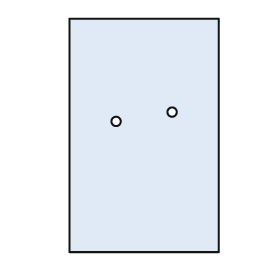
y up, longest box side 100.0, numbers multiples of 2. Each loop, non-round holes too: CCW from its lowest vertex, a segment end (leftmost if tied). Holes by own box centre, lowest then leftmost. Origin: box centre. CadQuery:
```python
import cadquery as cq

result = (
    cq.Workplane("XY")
    .moveTo(-32.0, -50.0)
    .lineTo(32.0, -50.0)
    .lineTo(32.0, 50.0)
    .lineTo(-32.0, 50.0)
    .close()
    .moveTo(-12.0, 6.0)
    .circle(2.0)
    .moveTo(12.0, 10.0)
    .circle(2.0)
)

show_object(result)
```